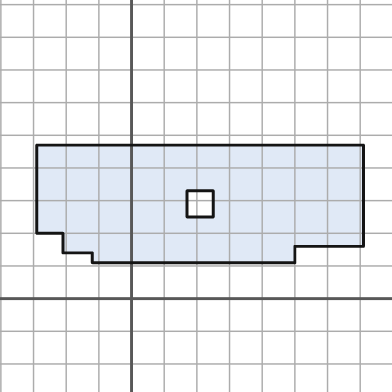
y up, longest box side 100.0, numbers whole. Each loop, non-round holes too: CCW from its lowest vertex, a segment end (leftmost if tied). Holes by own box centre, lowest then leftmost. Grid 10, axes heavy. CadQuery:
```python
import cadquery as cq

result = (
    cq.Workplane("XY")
    .moveTo(-12.0, 11.0)
    .lineTo(50.0, 11.0)
    .lineTo(50.0, 16.0)
    .lineTo(71.0, 16.0)
    .lineTo(71.0, 47.0)
    .lineTo(-29.0, 47.0)
    .lineTo(-29.0, 20.0)
    .lineTo(-21.0, 20.0)
    .lineTo(-21.0, 14.0)
    .lineTo(-12.0, 14.0)
    .close()
    .moveTo(17.0, 25.0)
    .lineTo(25.0, 25.0)
    .lineTo(25.0, 33.0)
    .lineTo(17.0, 33.0)
    .close()
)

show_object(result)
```